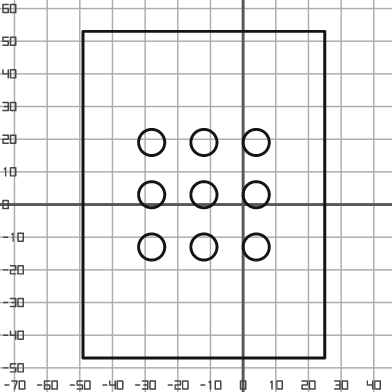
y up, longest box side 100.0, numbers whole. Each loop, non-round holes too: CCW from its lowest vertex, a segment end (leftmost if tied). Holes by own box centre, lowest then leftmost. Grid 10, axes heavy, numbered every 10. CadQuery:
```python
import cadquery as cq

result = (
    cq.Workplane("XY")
    .moveTo(-49.0, -47.0)
    .lineTo(25.0, -47.0)
    .lineTo(25.0, 53.0)
    .lineTo(-49.0, 53.0)
    .close()
    .moveTo(-28.0, -13.0)
    .circle(4.0)
    .moveTo(-12.0, -13.0)
    .circle(4.0)
    .moveTo(4.0, -13.0)
    .circle(4.0)
    .moveTo(-28.0, 3.0)
    .circle(4.0)
    .moveTo(-12.0, 3.0)
    .circle(4.0)
    .moveTo(4.0, 3.0)
    .circle(4.0)
    .moveTo(-28.0, 19.0)
    .circle(4.0)
    .moveTo(-12.0, 19.0)
    .circle(4.0)
    .moveTo(4.0, 19.0)
    .circle(4.0)
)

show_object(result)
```